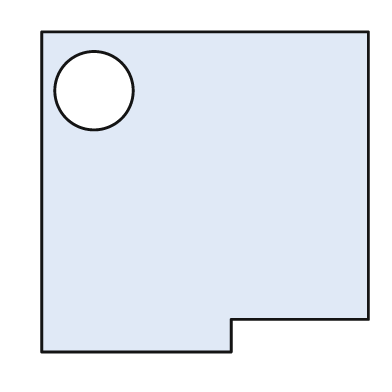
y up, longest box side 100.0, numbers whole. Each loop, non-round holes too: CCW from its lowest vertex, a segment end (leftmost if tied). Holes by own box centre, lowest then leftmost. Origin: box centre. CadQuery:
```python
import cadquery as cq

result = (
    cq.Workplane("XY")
    .moveTo(-50.0, -49.0)
    .lineTo(8.0, -49.0)
    .lineTo(8.0, -39.0)
    .lineTo(50.0, -39.0)
    .lineTo(50.0, 49.0)
    .lineTo(-50.0, 49.0)
    .close()
    .moveTo(-34.0, 31.0)
    .circle(12.0)
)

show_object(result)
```